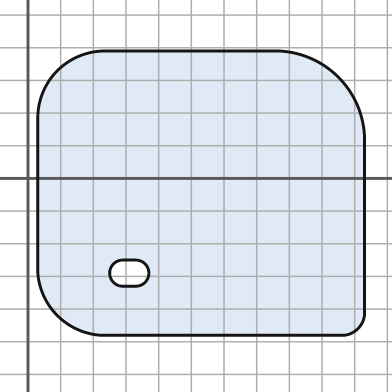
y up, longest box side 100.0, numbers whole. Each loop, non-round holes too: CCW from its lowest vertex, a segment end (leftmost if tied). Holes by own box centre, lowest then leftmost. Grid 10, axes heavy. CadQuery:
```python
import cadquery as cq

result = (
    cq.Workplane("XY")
    .moveTo(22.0, -48.0)
    .lineTo(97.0, -48.0)
    .threePointArc((101.0, -46.0), (103.0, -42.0))
    .lineTo(103.0, 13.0)
    .threePointArc((95.0, 31.0), (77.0, 39.0))
    .lineTo(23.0, 39.0)
    .threePointArc((9.0, 33.0), (3.0, 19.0))
    .lineTo(3.0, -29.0)
    .threePointArc((9.0, -42.0), (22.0, -48.0))
    .close()
    .moveTo(29.0, -33.0)
    .lineTo(33.0, -33.0)
    .threePointArc((37.0, -29.0), (33.0, -25.0))
    .lineTo(29.0, -25.0)
    .threePointArc((25.0, -29.0), (29.0, -33.0))
    .close()
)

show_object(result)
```